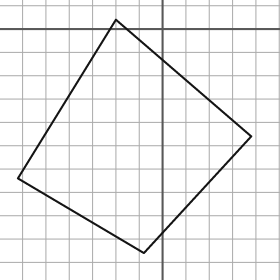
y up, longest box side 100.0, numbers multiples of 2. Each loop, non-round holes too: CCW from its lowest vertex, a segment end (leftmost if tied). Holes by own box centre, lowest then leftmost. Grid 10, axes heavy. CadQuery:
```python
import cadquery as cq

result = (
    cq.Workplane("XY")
    .moveTo(-8.0, -96.0)
    .lineTo(38.0, -46.0)
    .lineTo(-20.0, 4.0)
    .lineTo(-62.0, -64.0)
    .close()
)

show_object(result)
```